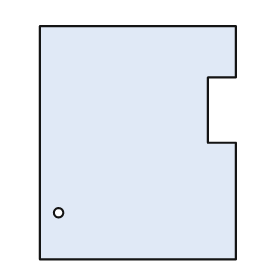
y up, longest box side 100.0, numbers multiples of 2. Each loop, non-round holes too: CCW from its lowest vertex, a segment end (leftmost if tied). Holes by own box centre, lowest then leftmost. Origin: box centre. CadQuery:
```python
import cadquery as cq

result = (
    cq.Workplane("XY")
    .moveTo(-42.0, -50.0)
    .lineTo(42.0, -50.0)
    .lineTo(42.0, 0.0)
    .lineTo(30.0, 0.0)
    .lineTo(30.0, 28.0)
    .lineTo(42.0, 28.0)
    .lineTo(42.0, 50.0)
    .lineTo(-42.0, 50.0)
    .close()
    .moveTo(-34.0, -30.0)
    .circle(2.0)
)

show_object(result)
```